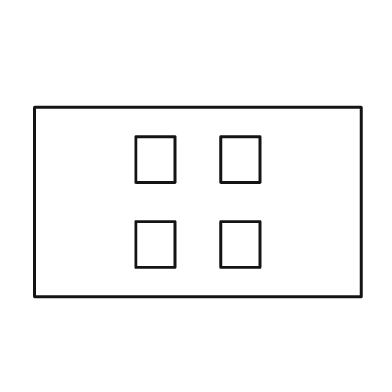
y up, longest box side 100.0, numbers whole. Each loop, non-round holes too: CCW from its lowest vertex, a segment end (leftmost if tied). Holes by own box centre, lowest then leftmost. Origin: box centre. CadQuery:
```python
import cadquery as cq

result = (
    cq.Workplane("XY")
    .moveTo(-50.0, -29.0)
    .lineTo(50.0, -29.0)
    .lineTo(50.0, 29.0)
    .lineTo(-50.0, 29.0)
    .close()
    .moveTo(-19.0, -20.0)
    .lineTo(-7.0, -20.0)
    .lineTo(-7.0, -6.0)
    .lineTo(-19.0, -6.0)
    .close()
    .moveTo(7.0, -20.0)
    .lineTo(19.0, -20.0)
    .lineTo(19.0, -6.0)
    .lineTo(7.0, -6.0)
    .close()
    .moveTo(-19.0, 6.0)
    .lineTo(-7.0, 6.0)
    .lineTo(-7.0, 20.0)
    .lineTo(-19.0, 20.0)
    .close()
    .moveTo(7.0, 6.0)
    .lineTo(19.0, 6.0)
    .lineTo(19.0, 20.0)
    .lineTo(7.0, 20.0)
    .close()
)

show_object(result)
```